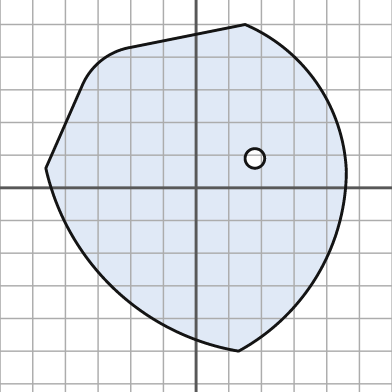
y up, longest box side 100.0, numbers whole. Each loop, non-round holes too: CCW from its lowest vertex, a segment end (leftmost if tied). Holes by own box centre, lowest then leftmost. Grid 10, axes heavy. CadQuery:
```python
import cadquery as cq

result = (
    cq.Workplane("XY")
    .moveTo(13.0, -50.0)
    .threePointArc((37.0, -27.0), (46.0, 5.0))
    .threePointArc((37.0, 32.0), (15.0, 50.0))
    .lineTo(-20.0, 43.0)
    .threePointArc((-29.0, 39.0), (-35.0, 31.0))
    .lineTo(-46.0, 6.0)
    .threePointArc((-25.0, -31.0), (13.0, -50.0))
    .close()
    .moveTo(18.0, 9.0)
    .circle(3.0)
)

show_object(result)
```